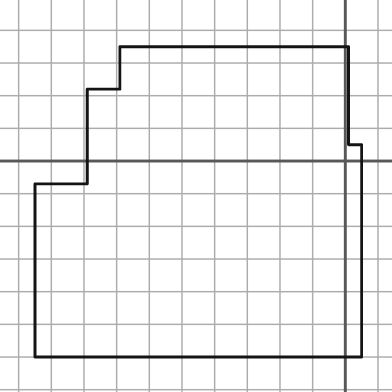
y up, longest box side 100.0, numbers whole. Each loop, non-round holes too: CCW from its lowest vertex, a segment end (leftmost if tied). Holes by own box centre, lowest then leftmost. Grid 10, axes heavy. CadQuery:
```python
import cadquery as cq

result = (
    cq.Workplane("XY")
    .moveTo(-95.0, -60.0)
    .lineTo(5.0, -60.0)
    .lineTo(5.0, 5.0)
    .lineTo(1.0, 5.0)
    .lineTo(1.0, 35.0)
    .lineTo(-69.0, 35.0)
    .lineTo(-69.0, 22.0)
    .lineTo(-79.0, 22.0)
    .lineTo(-79.0, -7.0)
    .lineTo(-95.0, -7.0)
    .close()
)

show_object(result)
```